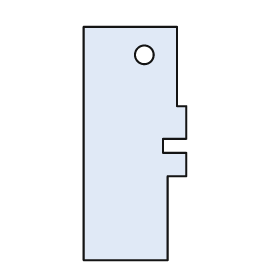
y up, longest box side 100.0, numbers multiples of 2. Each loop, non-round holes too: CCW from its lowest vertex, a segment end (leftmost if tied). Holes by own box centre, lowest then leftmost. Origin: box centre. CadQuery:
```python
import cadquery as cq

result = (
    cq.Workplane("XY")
    .moveTo(-22.0, -50.0)
    .lineTo(14.0, -50.0)
    .lineTo(14.0, -14.0)
    .lineTo(22.0, -14.0)
    .lineTo(22.0, -4.0)
    .lineTo(12.0, -4.0)
    .lineTo(12.0, 2.0)
    .lineTo(22.0, 2.0)
    .lineTo(22.0, 16.0)
    .lineTo(18.0, 16.0)
    .lineTo(18.0, 50.0)
    .lineTo(-22.0, 50.0)
    .close()
    .moveTo(4.0, 38.0)
    .circle(4.0)
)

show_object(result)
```